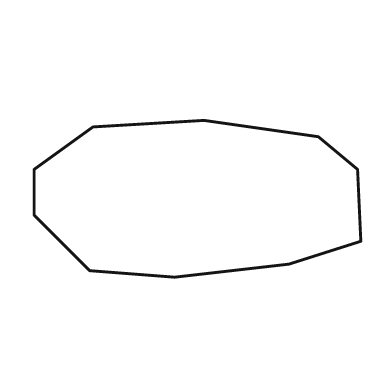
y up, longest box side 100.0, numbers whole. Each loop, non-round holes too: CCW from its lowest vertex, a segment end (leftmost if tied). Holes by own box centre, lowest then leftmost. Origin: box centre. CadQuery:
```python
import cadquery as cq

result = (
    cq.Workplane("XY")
    .moveTo(-7.0, -24.0)
    .lineTo(28.0, -20.0)
    .lineTo(50.0, -13.0)
    .lineTo(49.0, 9.0)
    .lineTo(37.0, 19.0)
    .lineTo(2.0, 24.0)
    .lineTo(-32.0, 22.0)
    .lineTo(-50.0, 9.0)
    .lineTo(-50.0, -5.0)
    .lineTo(-33.0, -22.0)
    .close()
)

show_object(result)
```